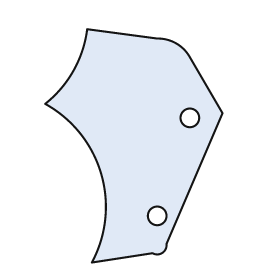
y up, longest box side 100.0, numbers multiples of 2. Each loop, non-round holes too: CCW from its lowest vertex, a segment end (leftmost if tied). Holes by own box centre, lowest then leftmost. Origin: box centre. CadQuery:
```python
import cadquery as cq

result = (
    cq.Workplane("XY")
    .moveTo(-18.0, -50.0)
    .lineTo(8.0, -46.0)
    .threePointArc((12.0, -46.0), (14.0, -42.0))
    .lineTo(38.0, 14.0)
    .lineTo(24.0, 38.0)
    .threePointArc((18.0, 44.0), (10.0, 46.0))
    .lineTo(-20.0, 50.0)
    .threePointArc((-26.0, 32.0), (-38.0, 18.0))
    .threePointArc((-14.0, -12.0), (-18.0, -50.0))
    .close()
    .moveTo(10.0, -30.0)
    .circle(4.0)
    .moveTo(24.0, 12.0)
    .circle(4.0)
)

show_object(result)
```